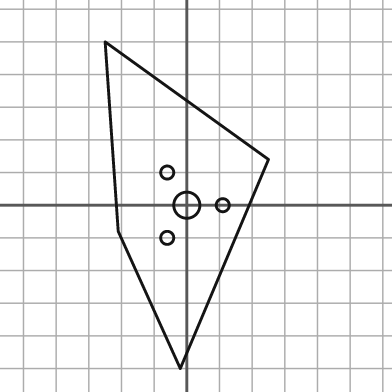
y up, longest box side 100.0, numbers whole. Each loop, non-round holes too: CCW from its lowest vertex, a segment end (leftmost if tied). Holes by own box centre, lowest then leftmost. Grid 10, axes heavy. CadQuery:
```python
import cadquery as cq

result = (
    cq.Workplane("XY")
    .moveTo(-2.0, -50.0)
    .lineTo(25.0, 14.0)
    .lineTo(-25.0, 50.0)
    .lineTo(-21.0, -8.0)
    .close()
    .moveTo(-6.0, -10.0)
    .circle(2.0)
    .moveTo(0.0, 0.0)
    .circle(4.0)
    .moveTo(11.0, 0.0)
    .circle(2.0)
    .moveTo(-6.0, 10.0)
    .circle(2.0)
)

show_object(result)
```